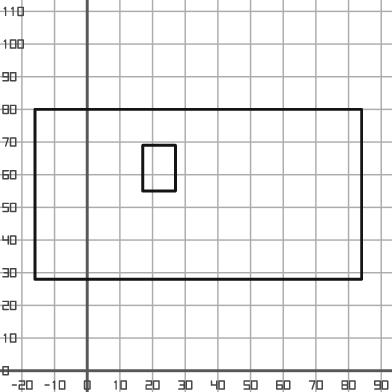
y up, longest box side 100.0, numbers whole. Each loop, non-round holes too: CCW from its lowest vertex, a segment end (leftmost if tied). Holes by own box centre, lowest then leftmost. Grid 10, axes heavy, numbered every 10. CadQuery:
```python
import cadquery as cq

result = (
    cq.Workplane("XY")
    .moveTo(-16.0, 28.0)
    .lineTo(84.0, 28.0)
    .lineTo(84.0, 80.0)
    .lineTo(-16.0, 80.0)
    .close()
    .moveTo(17.0, 55.0)
    .lineTo(27.0, 55.0)
    .lineTo(27.0, 69.0)
    .lineTo(17.0, 69.0)
    .close()
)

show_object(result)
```